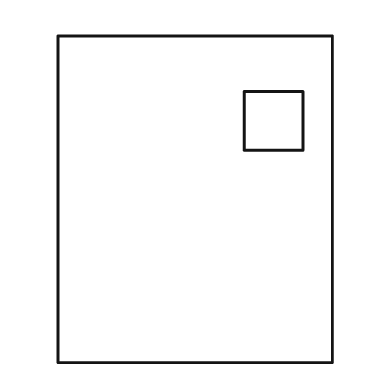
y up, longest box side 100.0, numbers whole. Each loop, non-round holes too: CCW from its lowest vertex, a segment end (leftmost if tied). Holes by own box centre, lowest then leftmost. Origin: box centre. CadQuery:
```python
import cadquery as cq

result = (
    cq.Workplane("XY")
    .moveTo(-42.0, -50.0)
    .lineTo(42.0, -50.0)
    .lineTo(42.0, 50.0)
    .lineTo(-42.0, 50.0)
    .close()
    .moveTo(15.0, 15.0)
    .lineTo(33.0, 15.0)
    .lineTo(33.0, 33.0)
    .lineTo(15.0, 33.0)
    .close()
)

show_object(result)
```